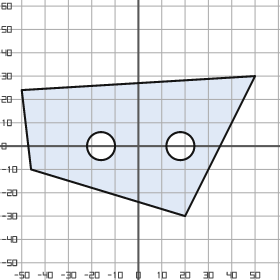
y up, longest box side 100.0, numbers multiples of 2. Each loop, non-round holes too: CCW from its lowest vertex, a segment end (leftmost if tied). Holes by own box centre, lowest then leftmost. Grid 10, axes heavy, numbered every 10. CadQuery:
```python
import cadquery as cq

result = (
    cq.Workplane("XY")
    .moveTo(20.0, -30.0)
    .lineTo(50.0, 30.0)
    .lineTo(-50.0, 24.0)
    .lineTo(-46.0, -10.0)
    .close()
    .moveTo(-16.0, 0.0)
    .circle(6.0)
    .moveTo(18.0, 0.0)
    .circle(6.0)
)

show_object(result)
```